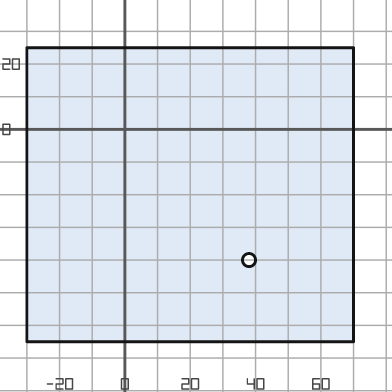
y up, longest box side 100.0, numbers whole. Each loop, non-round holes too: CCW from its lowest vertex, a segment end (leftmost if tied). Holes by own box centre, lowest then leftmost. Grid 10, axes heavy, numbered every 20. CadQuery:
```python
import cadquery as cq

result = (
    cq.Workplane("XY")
    .moveTo(-30.0, -65.0)
    .lineTo(70.0, -65.0)
    .lineTo(70.0, 25.0)
    .lineTo(-30.0, 25.0)
    .close()
    .moveTo(38.0, -40.0)
    .circle(2.0)
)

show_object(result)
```